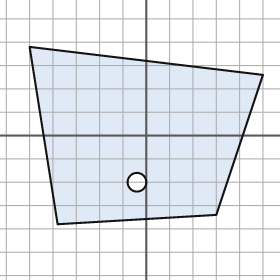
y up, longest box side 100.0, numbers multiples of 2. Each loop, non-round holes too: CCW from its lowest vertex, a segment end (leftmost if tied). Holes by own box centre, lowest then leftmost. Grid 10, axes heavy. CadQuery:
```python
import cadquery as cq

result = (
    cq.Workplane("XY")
    .moveTo(-38.0, -38.0)
    .lineTo(30.0, -34.0)
    .lineTo(50.0, 26.0)
    .lineTo(-50.0, 38.0)
    .close()
    .moveTo(-4.0, -20.0)
    .circle(4.0)
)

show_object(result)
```